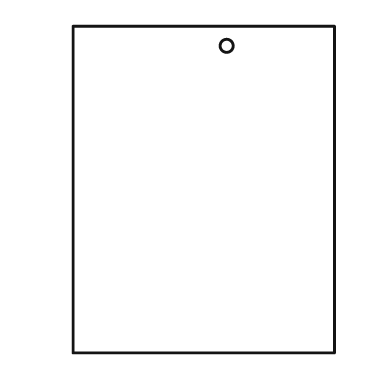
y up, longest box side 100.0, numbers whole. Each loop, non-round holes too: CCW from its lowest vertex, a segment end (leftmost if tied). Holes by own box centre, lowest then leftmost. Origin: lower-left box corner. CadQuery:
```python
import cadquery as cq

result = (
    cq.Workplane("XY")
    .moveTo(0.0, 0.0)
    .lineTo(80.0, 0.0)
    .lineTo(80.0, 100.0)
    .lineTo(0.0, 100.0)
    .close()
    .moveTo(47.0, 94.0)
    .circle(2.0)
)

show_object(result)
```